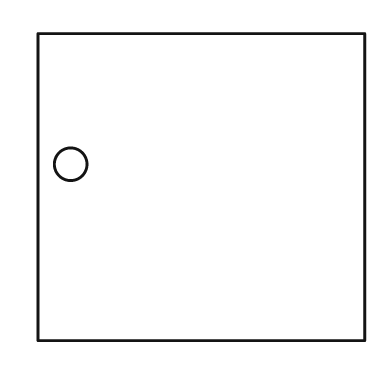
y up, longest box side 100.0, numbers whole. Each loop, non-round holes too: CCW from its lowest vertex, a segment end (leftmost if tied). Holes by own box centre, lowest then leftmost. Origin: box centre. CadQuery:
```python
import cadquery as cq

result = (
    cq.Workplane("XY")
    .moveTo(-50.0, -47.0)
    .lineTo(50.0, -47.0)
    .lineTo(50.0, 47.0)
    .lineTo(-50.0, 47.0)
    .close()
    .moveTo(-40.0, 7.0)
    .circle(5.0)
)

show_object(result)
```